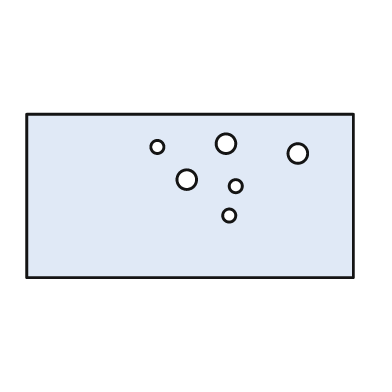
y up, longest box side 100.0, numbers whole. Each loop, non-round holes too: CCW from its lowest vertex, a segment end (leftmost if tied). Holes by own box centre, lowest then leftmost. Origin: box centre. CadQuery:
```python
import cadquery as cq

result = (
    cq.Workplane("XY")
    .moveTo(-50.0, -25.0)
    .lineTo(50.0, -25.0)
    .lineTo(50.0, 25.0)
    .lineTo(-50.0, 25.0)
    .close()
    .moveTo(12.0, -6.0)
    .circle(2.0)
    .moveTo(14.0, 3.0)
    .circle(2.0)
    .moveTo(-1.0, 5.0)
    .circle(3.0)
    .moveTo(33.0, 13.0)
    .circle(3.0)
    .moveTo(-10.0, 15.0)
    .circle(2.0)
    .moveTo(11.0, 16.0)
    .circle(3.0)
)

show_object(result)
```